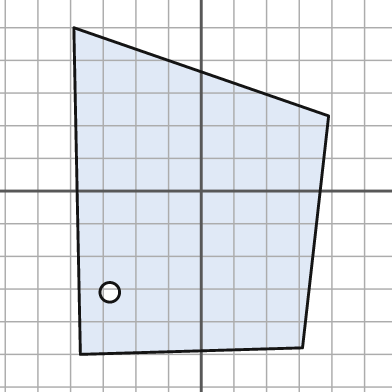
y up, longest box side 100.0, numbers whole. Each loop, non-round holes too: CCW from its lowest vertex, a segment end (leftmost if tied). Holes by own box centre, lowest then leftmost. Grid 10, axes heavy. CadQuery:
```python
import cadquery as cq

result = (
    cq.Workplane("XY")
    .moveTo(-37.0, -50.0)
    .lineTo(31.0, -48.0)
    .lineTo(39.0, 23.0)
    .lineTo(-39.0, 50.0)
    .close()
    .moveTo(-28.0, -31.0)
    .circle(3.0)
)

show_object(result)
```